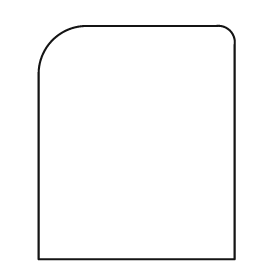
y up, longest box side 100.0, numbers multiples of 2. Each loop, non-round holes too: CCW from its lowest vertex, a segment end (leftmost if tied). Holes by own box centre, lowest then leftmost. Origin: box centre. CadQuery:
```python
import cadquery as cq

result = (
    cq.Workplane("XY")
    .moveTo(-42.0, -50.0)
    .lineTo(42.0, -50.0)
    .lineTo(42.0, 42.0)
    .threePointArc((40.0, 48.0), (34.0, 50.0))
    .lineTo(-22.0, 50.0)
    .threePointArc((-36.0, 44.0), (-42.0, 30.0))
    .close()
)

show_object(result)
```